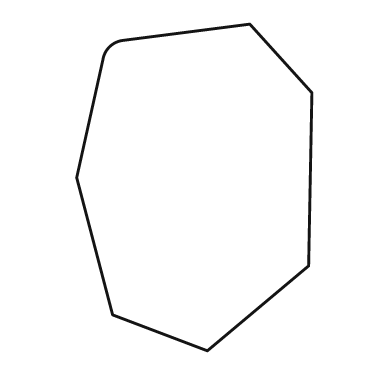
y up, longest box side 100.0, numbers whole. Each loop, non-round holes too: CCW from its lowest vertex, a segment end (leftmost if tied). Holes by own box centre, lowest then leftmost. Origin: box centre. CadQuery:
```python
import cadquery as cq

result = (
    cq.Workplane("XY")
    .moveTo(4.0, -50.0)
    .lineTo(35.0, -24.0)
    .lineTo(36.0, 29.0)
    .lineTo(17.0, 50.0)
    .lineTo(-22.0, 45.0)
    .threePointArc((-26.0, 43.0), (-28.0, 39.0))
    .lineTo(-36.0, 3.0)
    .lineTo(-25.0, -39.0)
    .close()
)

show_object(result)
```